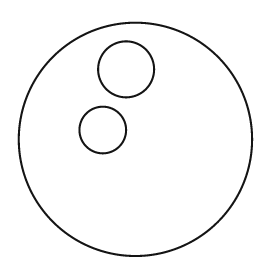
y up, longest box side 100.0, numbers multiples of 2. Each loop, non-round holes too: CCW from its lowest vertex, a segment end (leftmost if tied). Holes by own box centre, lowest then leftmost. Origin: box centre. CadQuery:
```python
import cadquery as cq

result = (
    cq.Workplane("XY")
    .moveTo(0.0, 0.0)
    .circle(50.0)
    .moveTo(-14.0, 4.0)
    .circle(10.0)
    .moveTo(-4.0, 30.0)
    .circle(12.0)
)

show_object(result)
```